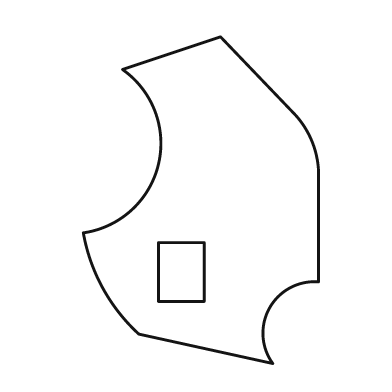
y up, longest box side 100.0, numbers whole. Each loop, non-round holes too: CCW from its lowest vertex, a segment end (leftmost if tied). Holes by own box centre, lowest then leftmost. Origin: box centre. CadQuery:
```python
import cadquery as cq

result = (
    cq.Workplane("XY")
    .moveTo(22.0, -50.0)
    .threePointArc((21.0, -33.0), (36.0, -25.0))
    .lineTo(36.0, 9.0)
    .threePointArc((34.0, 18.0), (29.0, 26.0))
    .lineTo(6.0, 50.0)
    .lineTo(-24.0, 40.0)
    .threePointArc((-13.0, 11.0), (-36.0, -10.0))
    .threePointArc((-30.0, -27.0), (-19.0, -41.0))
    .close()
    .moveTo(-13.0, -31.0)
    .lineTo(1.0, -31.0)
    .lineTo(1.0, -13.0)
    .lineTo(-13.0, -13.0)
    .close()
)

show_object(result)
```